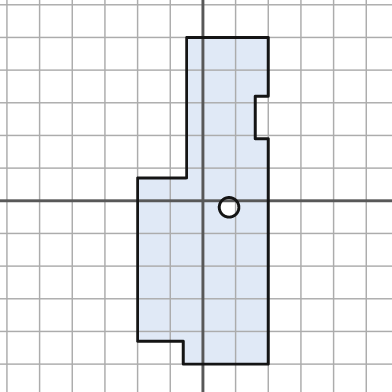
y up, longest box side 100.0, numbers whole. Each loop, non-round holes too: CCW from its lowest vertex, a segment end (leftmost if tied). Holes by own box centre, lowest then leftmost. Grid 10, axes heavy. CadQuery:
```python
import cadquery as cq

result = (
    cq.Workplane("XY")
    .moveTo(-6.0, -50.0)
    .lineTo(20.0, -50.0)
    .lineTo(20.0, 19.0)
    .lineTo(16.0, 19.0)
    .lineTo(16.0, 32.0)
    .lineTo(20.0, 32.0)
    .lineTo(20.0, 50.0)
    .lineTo(-5.0, 50.0)
    .lineTo(-5.0, 7.0)
    .lineTo(-20.0, 7.0)
    .lineTo(-20.0, -43.0)
    .lineTo(-6.0, -43.0)
    .close()
    .moveTo(8.0, -2.0)
    .circle(3.0)
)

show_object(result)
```